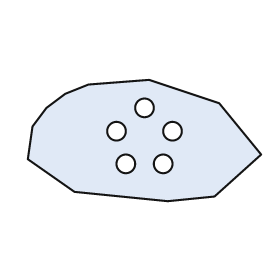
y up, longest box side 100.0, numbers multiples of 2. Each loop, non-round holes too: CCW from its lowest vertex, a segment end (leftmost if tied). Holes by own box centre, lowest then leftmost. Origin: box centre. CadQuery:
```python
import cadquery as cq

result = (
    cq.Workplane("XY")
    .moveTo(10.0, -26.0)
    .lineTo(30.0, -24.0)
    .lineTo(50.0, -6.0)
    .lineTo(32.0, 16.0)
    .lineTo(2.0, 26.0)
    .lineTo(-24.0, 24.0)
    .lineTo(-34.0, 20.0)
    .lineTo(-42.0, 14.0)
    .lineTo(-48.0, 6.0)
    .lineTo(-50.0, -8.0)
    .lineTo(-30.0, -22.0)
    .close()
    .moveTo(-8.0, -10.0)
    .circle(4.0)
    .moveTo(8.0, -10.0)
    .circle(4.0)
    .moveTo(-12.0, 4.0)
    .circle(4.0)
    .moveTo(12.0, 4.0)
    .circle(4.0)
    .moveTo(0.0, 14.0)
    .circle(4.0)
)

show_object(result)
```